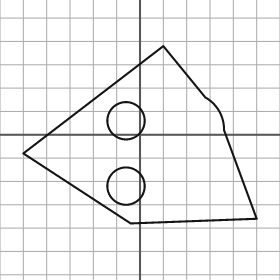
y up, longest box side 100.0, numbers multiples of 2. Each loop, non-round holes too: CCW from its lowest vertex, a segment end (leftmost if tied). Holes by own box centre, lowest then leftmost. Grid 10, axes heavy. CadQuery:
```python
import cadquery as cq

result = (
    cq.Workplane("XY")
    .moveTo(-4.0, -38.0)
    .lineTo(50.0, -36.0)
    .lineTo(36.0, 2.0)
    .threePointArc((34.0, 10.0), (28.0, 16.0))
    .lineTo(10.0, 38.0)
    .lineTo(-50.0, -8.0)
    .close()
    .moveTo(-6.0, -22.0)
    .circle(8.0)
    .moveTo(-6.0, 6.0)
    .circle(8.0)
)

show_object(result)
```